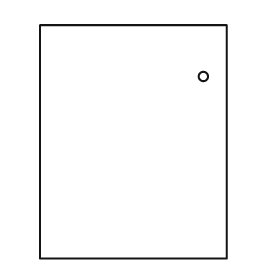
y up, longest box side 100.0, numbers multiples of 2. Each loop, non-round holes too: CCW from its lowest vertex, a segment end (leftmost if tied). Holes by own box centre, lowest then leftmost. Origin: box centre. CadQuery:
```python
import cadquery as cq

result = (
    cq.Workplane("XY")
    .moveTo(-40.0, -50.0)
    .lineTo(40.0, -50.0)
    .lineTo(40.0, 50.0)
    .lineTo(-40.0, 50.0)
    .close()
    .moveTo(30.0, 28.0)
    .circle(2.0)
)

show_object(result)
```